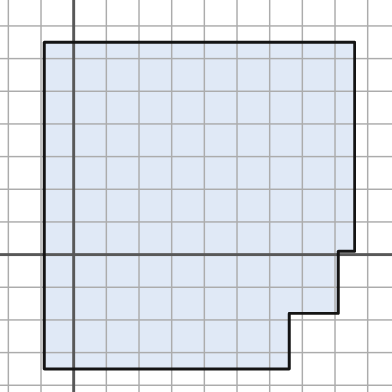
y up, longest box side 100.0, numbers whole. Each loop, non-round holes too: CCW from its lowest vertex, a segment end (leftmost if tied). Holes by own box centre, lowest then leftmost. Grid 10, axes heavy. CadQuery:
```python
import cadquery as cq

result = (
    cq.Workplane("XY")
    .moveTo(-9.0, -35.0)
    .lineTo(66.0, -35.0)
    .lineTo(66.0, -18.0)
    .lineTo(81.0, -18.0)
    .lineTo(81.0, 1.0)
    .lineTo(86.0, 1.0)
    .lineTo(86.0, 65.0)
    .lineTo(-9.0, 65.0)
    .close()
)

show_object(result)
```